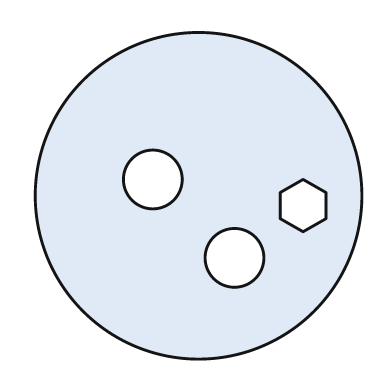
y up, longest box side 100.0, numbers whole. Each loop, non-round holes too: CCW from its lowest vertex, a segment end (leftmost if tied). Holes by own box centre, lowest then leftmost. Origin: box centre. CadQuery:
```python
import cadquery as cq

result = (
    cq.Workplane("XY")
    .moveTo(0.0, 0.0)
    .circle(50.0)
    .moveTo(11.0, -19.0)
    .circle(9.0)
    .moveTo(32.0, -11.0)
    .lineTo(39.0, -7.0)
    .lineTo(39.0, 1.0)
    .lineTo(32.0, 5.0)
    .lineTo(25.0, 1.0)
    .lineTo(25.0, -7.0)
    .close()
    .moveTo(-14.0, 5.0)
    .circle(9.0)
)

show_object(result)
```